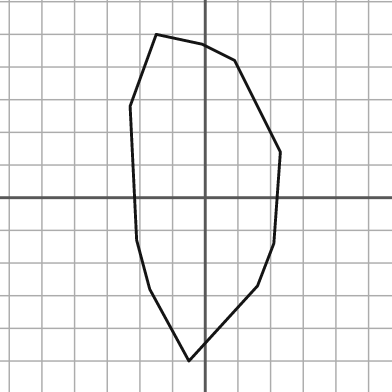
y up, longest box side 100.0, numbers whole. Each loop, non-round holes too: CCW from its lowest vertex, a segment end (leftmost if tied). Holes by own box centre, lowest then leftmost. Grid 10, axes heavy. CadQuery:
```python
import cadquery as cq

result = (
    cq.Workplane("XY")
    .moveTo(-5.0, -50.0)
    .lineTo(16.0, -27.0)
    .lineTo(21.0, -14.0)
    .lineTo(23.0, 14.0)
    .lineTo(9.0, 42.0)
    .lineTo(-1.0, 47.0)
    .lineTo(-15.0, 50.0)
    .lineTo(-23.0, 28.0)
    .lineTo(-21.0, -13.0)
    .lineTo(-17.0, -28.0)
    .close()
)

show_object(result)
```